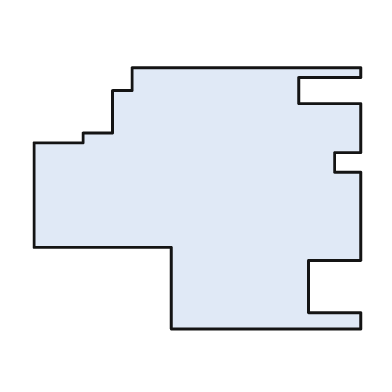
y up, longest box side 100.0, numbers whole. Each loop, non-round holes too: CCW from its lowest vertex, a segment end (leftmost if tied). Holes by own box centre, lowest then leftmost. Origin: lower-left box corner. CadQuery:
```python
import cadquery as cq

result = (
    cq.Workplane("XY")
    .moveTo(42.0, 0.0)
    .lineTo(100.0, 0.0)
    .lineTo(100.0, 5.0)
    .lineTo(84.0, 5.0)
    .lineTo(84.0, 21.0)
    .lineTo(100.0, 21.0)
    .lineTo(100.0, 48.0)
    .lineTo(92.0, 48.0)
    .lineTo(92.0, 54.0)
    .lineTo(100.0, 54.0)
    .lineTo(100.0, 69.0)
    .lineTo(81.0, 69.0)
    .lineTo(81.0, 77.0)
    .lineTo(100.0, 77.0)
    .lineTo(100.0, 80.0)
    .lineTo(30.0, 80.0)
    .lineTo(30.0, 73.0)
    .lineTo(24.0, 73.0)
    .lineTo(24.0, 60.0)
    .lineTo(15.0, 60.0)
    .lineTo(15.0, 57.0)
    .lineTo(0.0, 57.0)
    .lineTo(0.0, 25.0)
    .lineTo(42.0, 25.0)
    .close()
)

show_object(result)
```